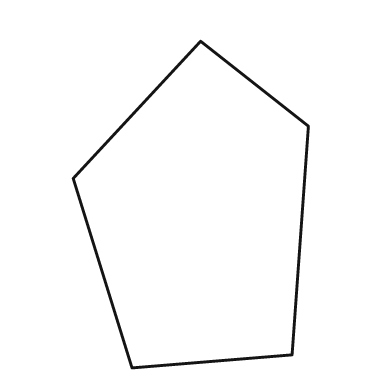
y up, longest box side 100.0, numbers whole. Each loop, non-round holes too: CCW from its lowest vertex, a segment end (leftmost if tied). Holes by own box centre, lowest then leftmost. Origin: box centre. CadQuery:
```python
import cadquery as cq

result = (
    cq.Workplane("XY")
    .moveTo(-18.0, -50.0)
    .lineTo(31.0, -46.0)
    .lineTo(36.0, 24.0)
    .lineTo(3.0, 50.0)
    .lineTo(-36.0, 8.0)
    .close()
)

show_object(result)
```